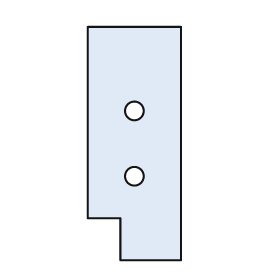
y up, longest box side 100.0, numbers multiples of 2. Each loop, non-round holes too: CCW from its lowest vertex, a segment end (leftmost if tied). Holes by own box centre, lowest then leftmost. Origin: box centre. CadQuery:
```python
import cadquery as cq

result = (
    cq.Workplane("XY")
    .moveTo(-6.0, -50.0)
    .lineTo(20.0, -50.0)
    .lineTo(20.0, 50.0)
    .lineTo(-20.0, 50.0)
    .lineTo(-20.0, -32.0)
    .lineTo(-6.0, -32.0)
    .close()
    .moveTo(0.0, -14.0)
    .circle(4.0)
    .moveTo(0.0, 14.0)
    .circle(4.0)
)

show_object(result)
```